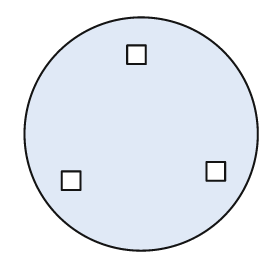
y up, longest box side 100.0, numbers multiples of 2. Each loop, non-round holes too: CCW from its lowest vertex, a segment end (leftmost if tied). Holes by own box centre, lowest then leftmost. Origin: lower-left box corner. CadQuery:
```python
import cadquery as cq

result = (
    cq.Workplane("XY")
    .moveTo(50.0, 50.0)
    .circle(50.0)
    .moveTo(16.0, 26.0)
    .lineTo(24.0, 26.0)
    .lineTo(24.0, 34.0)
    .lineTo(16.0, 34.0)
    .close()
    .moveTo(78.0, 30.0)
    .lineTo(86.0, 30.0)
    .lineTo(86.0, 38.0)
    .lineTo(78.0, 38.0)
    .close()
    .moveTo(44.0, 80.0)
    .lineTo(52.0, 80.0)
    .lineTo(52.0, 88.0)
    .lineTo(44.0, 88.0)
    .close()
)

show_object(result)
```